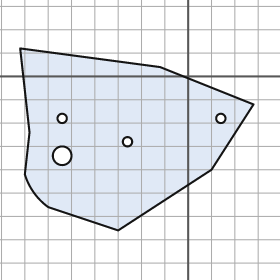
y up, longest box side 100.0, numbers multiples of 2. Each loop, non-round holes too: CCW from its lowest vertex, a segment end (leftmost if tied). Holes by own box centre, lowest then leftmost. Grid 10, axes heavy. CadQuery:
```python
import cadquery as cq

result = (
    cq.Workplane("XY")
    .moveTo(-30.0, -66.0)
    .lineTo(10.0, -40.0)
    .lineTo(28.0, -12.0)
    .lineTo(-12.0, 4.0)
    .lineTo(-72.0, 12.0)
    .lineTo(-68.0, -24.0)
    .lineTo(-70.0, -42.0)
    .threePointArc((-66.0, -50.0), (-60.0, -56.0))
    .close()
    .moveTo(-54.0, -34.0)
    .circle(4.0)
    .moveTo(-26.0, -28.0)
    .circle(2.0)
    .moveTo(-54.0, -18.0)
    .circle(2.0)
    .moveTo(14.0, -18.0)
    .circle(2.0)
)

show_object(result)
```